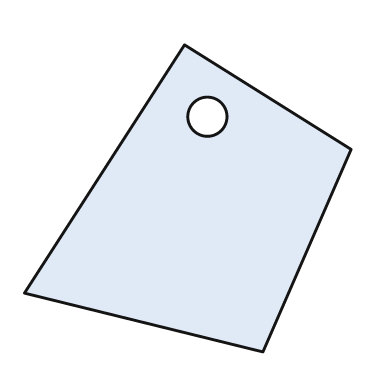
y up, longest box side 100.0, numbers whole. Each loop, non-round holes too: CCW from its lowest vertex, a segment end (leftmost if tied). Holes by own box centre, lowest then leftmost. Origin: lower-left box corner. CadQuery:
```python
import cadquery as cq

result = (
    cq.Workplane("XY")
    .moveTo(73.0, 0.0)
    .lineTo(100.0, 62.0)
    .lineTo(49.0, 94.0)
    .lineTo(0.0, 18.0)
    .close()
    .moveTo(56.0, 72.0)
    .circle(6.0)
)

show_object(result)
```